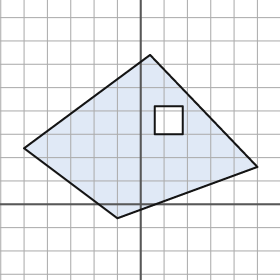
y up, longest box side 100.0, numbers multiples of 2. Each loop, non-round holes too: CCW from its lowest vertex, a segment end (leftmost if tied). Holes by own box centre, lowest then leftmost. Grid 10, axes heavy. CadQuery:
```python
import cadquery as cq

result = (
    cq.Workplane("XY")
    .moveTo(-10.0, -6.0)
    .lineTo(50.0, 16.0)
    .lineTo(4.0, 64.0)
    .lineTo(-50.0, 24.0)
    .close()
    .moveTo(6.0, 30.0)
    .lineTo(18.0, 30.0)
    .lineTo(18.0, 42.0)
    .lineTo(6.0, 42.0)
    .close()
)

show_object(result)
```